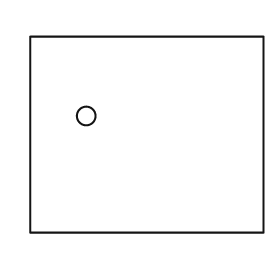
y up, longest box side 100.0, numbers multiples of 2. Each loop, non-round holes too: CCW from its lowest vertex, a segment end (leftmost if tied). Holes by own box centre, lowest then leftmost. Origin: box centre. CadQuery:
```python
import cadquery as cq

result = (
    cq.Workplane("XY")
    .moveTo(-50.0, -42.0)
    .lineTo(50.0, -42.0)
    .lineTo(50.0, 42.0)
    .lineTo(-50.0, 42.0)
    .close()
    .moveTo(-26.0, 8.0)
    .circle(4.0)
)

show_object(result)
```